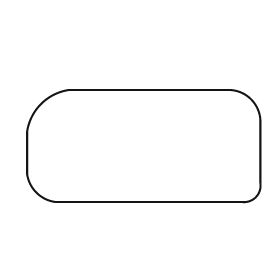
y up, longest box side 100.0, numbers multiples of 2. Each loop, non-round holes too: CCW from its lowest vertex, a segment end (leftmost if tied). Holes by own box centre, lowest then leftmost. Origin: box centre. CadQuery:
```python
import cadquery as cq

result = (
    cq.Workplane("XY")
    .moveTo(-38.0, -24.0)
    .lineTo(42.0, -24.0)
    .threePointArc((48.0, -22.0), (50.0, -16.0))
    .lineTo(50.0, 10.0)
    .threePointArc((46.0, 20.0), (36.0, 24.0))
    .lineTo(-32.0, 24.0)
    .threePointArc((-44.0, 18.0), (-50.0, 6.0))
    .lineTo(-50.0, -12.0)
    .threePointArc((-46.0, -20.0), (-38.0, -24.0))
    .close()
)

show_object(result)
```